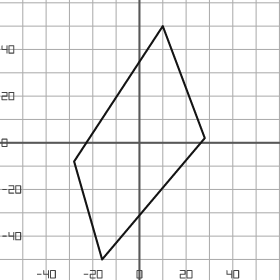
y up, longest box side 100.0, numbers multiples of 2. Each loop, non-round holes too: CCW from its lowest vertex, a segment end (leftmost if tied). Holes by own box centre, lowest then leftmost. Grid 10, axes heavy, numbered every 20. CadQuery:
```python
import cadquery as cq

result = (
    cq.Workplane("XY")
    .moveTo(-16.0, -50.0)
    .lineTo(28.0, 2.0)
    .lineTo(10.0, 50.0)
    .lineTo(-28.0, -8.0)
    .close()
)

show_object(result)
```